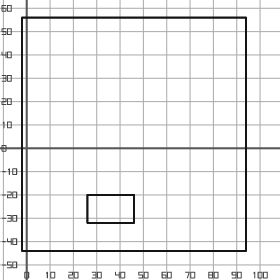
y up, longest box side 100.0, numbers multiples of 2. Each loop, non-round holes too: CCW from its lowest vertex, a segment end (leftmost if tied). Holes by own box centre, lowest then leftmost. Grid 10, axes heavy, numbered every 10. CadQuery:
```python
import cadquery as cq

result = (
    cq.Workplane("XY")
    .moveTo(-2.0, -44.0)
    .lineTo(94.0, -44.0)
    .lineTo(94.0, 56.0)
    .lineTo(-2.0, 56.0)
    .close()
    .moveTo(26.0, -32.0)
    .lineTo(46.0, -32.0)
    .lineTo(46.0, -20.0)
    .lineTo(26.0, -20.0)
    .close()
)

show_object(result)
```